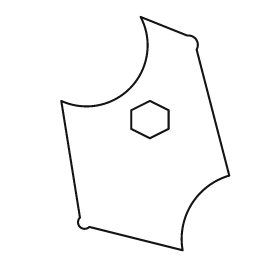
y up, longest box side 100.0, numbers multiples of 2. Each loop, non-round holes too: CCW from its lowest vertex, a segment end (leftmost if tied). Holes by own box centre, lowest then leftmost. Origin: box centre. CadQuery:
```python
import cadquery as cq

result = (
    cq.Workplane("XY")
    .moveTo(16.0, -50.0)
    .threePointArc((20.0, -30.0), (36.0, -18.0))
    .lineTo(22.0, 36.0)
    .threePointArc((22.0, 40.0), (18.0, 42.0))
    .lineTo(-2.0, 50.0)
    .threePointArc((-6.0, 20.0), (-36.0, 14.0))
    .lineTo(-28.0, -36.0)
    .threePointArc((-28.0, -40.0), (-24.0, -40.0))
    .close()
    .moveTo(2.0, -2.0)
    .lineTo(10.0, 2.0)
    .lineTo(10.0, 10.0)
    .lineTo(2.0, 14.0)
    .lineTo(-6.0, 10.0)
    .lineTo(-6.0, 2.0)
    .close()
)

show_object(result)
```